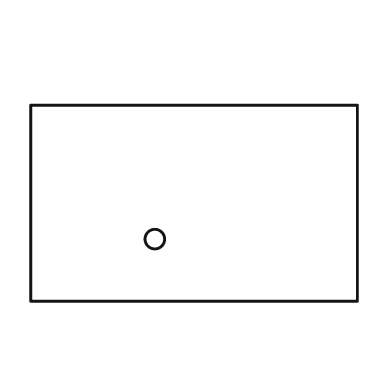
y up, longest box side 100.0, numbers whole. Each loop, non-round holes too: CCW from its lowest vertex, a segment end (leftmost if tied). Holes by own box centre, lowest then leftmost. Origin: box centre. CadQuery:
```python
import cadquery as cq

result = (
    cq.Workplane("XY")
    .moveTo(-50.0, -30.0)
    .lineTo(50.0, -30.0)
    .lineTo(50.0, 30.0)
    .lineTo(-50.0, 30.0)
    .close()
    .moveTo(-12.0, -11.0)
    .circle(3.0)
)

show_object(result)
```